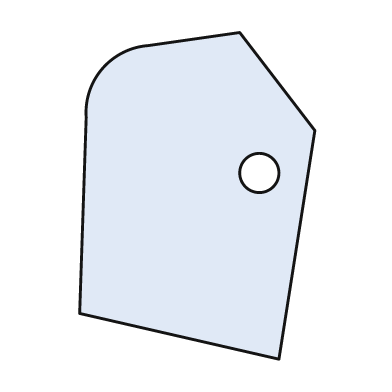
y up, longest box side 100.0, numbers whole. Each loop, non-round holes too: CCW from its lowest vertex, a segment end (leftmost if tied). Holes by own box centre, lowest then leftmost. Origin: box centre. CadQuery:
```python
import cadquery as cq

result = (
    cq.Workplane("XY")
    .moveTo(25.0, -50.0)
    .lineTo(36.0, 20.0)
    .lineTo(13.0, 50.0)
    .lineTo(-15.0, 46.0)
    .threePointArc((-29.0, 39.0), (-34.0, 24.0))
    .lineTo(-36.0, -36.0)
    .close()
    .moveTo(19.0, 7.0)
    .circle(6.0)
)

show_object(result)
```